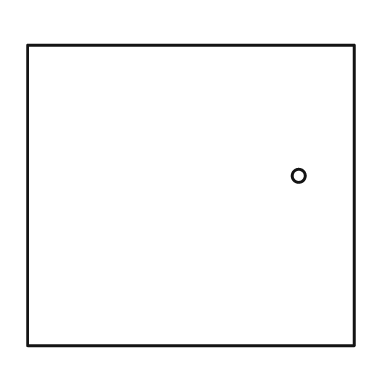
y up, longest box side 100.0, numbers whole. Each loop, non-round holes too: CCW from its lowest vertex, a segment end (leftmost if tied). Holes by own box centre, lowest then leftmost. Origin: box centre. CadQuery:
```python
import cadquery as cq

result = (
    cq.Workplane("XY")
    .moveTo(-50.0, -46.0)
    .lineTo(50.0, -46.0)
    .lineTo(50.0, 46.0)
    .lineTo(-50.0, 46.0)
    .close()
    .moveTo(33.0, 6.0)
    .circle(2.0)
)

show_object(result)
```